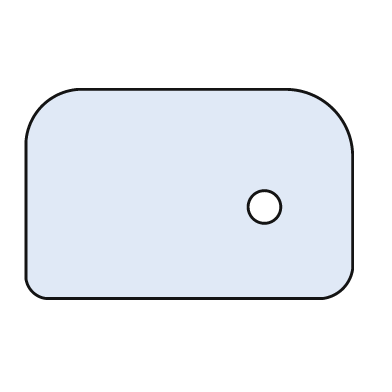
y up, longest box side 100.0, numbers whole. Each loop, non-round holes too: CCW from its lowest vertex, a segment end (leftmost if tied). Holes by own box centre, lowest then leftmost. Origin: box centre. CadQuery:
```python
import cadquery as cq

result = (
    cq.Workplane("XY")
    .moveTo(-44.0, -32.0)
    .lineTo(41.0, -32.0)
    .threePointArc((47.0, -29.0), (50.0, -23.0))
    .lineTo(50.0, 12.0)
    .threePointArc((44.0, 26.0), (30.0, 32.0))
    .lineTo(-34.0, 32.0)
    .threePointArc((-45.0, 27.0), (-50.0, 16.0))
    .lineTo(-50.0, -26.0)
    .threePointArc((-48.0, -30.0), (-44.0, -32.0))
    .close()
    .moveTo(23.0, -4.0)
    .circle(5.0)
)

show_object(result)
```